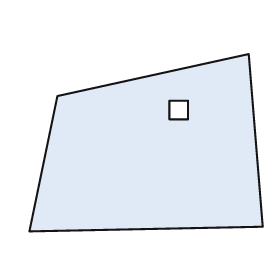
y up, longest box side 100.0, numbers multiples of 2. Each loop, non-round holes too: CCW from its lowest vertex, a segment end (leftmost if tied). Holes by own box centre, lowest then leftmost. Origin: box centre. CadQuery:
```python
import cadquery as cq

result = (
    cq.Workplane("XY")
    .moveTo(-50.0, -38.0)
    .lineTo(50.0, -36.0)
    .lineTo(44.0, 38.0)
    .lineTo(-38.0, 20.0)
    .close()
    .moveTo(10.0, 10.0)
    .lineTo(18.0, 10.0)
    .lineTo(18.0, 18.0)
    .lineTo(10.0, 18.0)
    .close()
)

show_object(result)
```